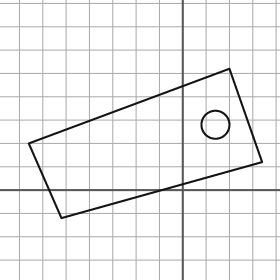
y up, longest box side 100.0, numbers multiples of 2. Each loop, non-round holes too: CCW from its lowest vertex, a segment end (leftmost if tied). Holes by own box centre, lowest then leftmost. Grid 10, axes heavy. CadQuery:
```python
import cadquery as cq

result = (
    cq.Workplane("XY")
    .moveTo(-52.0, -12.0)
    .lineTo(34.0, 12.0)
    .lineTo(20.0, 52.0)
    .lineTo(-66.0, 20.0)
    .close()
    .moveTo(14.0, 28.0)
    .circle(6.0)
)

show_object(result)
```